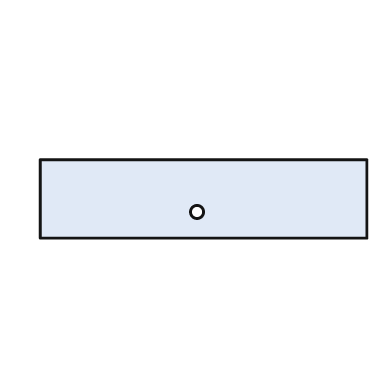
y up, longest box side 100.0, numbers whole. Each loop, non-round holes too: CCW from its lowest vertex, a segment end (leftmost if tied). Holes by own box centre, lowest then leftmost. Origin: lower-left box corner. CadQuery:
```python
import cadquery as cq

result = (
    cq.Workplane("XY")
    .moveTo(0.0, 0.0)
    .lineTo(100.0, 0.0)
    .lineTo(100.0, 24.0)
    .lineTo(0.0, 24.0)
    .close()
    .moveTo(48.0, 8.0)
    .circle(2.0)
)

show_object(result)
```